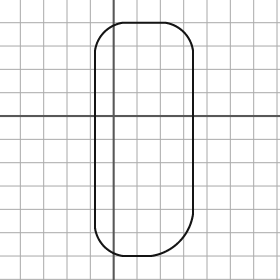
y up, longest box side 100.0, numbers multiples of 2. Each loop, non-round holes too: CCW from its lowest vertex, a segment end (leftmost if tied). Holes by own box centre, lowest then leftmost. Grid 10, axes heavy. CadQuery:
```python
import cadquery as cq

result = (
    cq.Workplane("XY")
    .moveTo(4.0, -60.0)
    .lineTo(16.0, -60.0)
    .threePointArc((28.0, -54.0), (34.0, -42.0))
    .lineTo(34.0, 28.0)
    .threePointArc((30.0, 36.0), (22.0, 40.0))
    .lineTo(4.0, 40.0)
    .threePointArc((-4.0, 36.0), (-8.0, 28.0))
    .lineTo(-8.0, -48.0)
    .threePointArc((-4.0, -56.0), (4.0, -60.0))
    .close()
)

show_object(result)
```